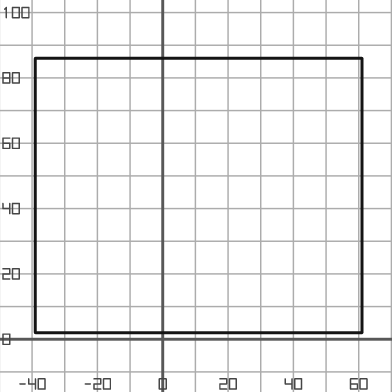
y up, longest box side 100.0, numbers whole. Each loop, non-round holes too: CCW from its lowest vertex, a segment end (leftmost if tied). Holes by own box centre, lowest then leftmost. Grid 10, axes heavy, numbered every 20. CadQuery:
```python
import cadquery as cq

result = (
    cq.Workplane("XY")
    .moveTo(-39.0, 2.0)
    .lineTo(61.0, 2.0)
    .lineTo(61.0, 86.0)
    .lineTo(-39.0, 86.0)
    .close()
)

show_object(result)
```